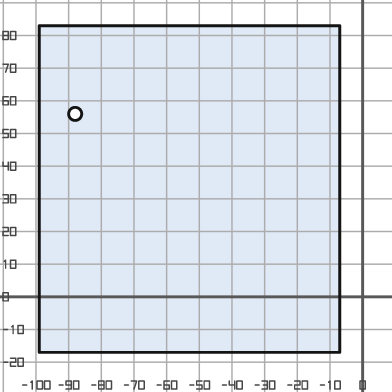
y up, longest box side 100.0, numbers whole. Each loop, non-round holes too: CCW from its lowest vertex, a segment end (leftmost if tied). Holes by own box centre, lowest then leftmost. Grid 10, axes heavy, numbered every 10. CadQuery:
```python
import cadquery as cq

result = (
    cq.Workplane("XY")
    .moveTo(-99.0, -17.0)
    .lineTo(-7.0, -17.0)
    .lineTo(-7.0, 83.0)
    .lineTo(-99.0, 83.0)
    .close()
    .moveTo(-88.0, 56.0)
    .circle(2.0)
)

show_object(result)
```